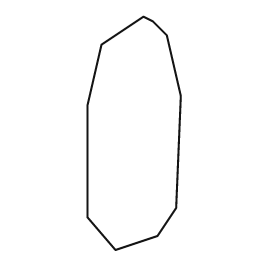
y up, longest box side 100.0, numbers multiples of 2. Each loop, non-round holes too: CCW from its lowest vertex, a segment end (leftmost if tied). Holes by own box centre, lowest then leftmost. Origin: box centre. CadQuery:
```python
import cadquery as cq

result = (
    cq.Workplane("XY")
    .moveTo(-8.0, -50.0)
    .lineTo(10.0, -44.0)
    .lineTo(18.0, -32.0)
    .lineTo(20.0, 16.0)
    .lineTo(14.0, 42.0)
    .lineTo(8.0, 48.0)
    .lineTo(4.0, 50.0)
    .lineTo(-14.0, 38.0)
    .lineTo(-20.0, 12.0)
    .lineTo(-20.0, -36.0)
    .close()
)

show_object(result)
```